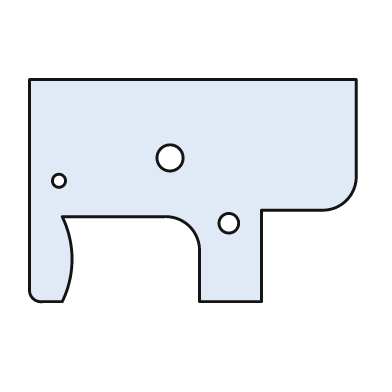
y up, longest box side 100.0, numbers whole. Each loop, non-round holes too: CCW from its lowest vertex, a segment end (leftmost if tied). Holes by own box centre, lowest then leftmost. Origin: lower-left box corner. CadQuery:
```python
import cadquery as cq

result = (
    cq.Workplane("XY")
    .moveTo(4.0, 0.0)
    .lineTo(10.0, 0.0)
    .threePointArc((13.0, 13.0), (10.0, 26.0))
    .lineTo(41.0, 26.0)
    .threePointArc((49.0, 23.0), (52.0, 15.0))
    .lineTo(52.0, 0.0)
    .lineTo(71.0, 0.0)
    .lineTo(71.0, 28.0)
    .lineTo(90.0, 28.0)
    .threePointArc((97.0, 31.0), (100.0, 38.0))
    .lineTo(100.0, 68.0)
    .lineTo(0.0, 68.0)
    .lineTo(0.0, 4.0)
    .threePointArc((1.0, 1.0), (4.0, 0.0))
    .close()
    .moveTo(61.0, 24.0)
    .circle(3.0)
    .moveTo(9.0, 37.0)
    .circle(2.0)
    .moveTo(43.0, 44.0)
    .circle(4.0)
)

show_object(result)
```